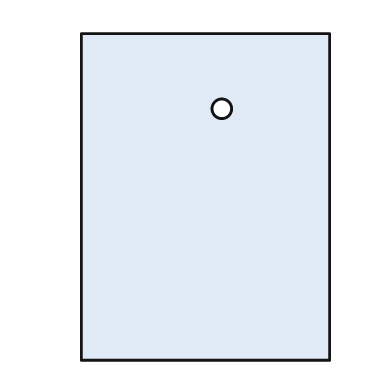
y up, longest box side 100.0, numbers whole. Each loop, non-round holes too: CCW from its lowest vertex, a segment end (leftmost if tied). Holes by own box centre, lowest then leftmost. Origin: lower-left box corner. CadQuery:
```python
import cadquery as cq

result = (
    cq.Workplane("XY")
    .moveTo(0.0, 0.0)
    .lineTo(76.0, 0.0)
    .lineTo(76.0, 100.0)
    .lineTo(0.0, 100.0)
    .close()
    .moveTo(43.0, 77.0)
    .circle(3.0)
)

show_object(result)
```